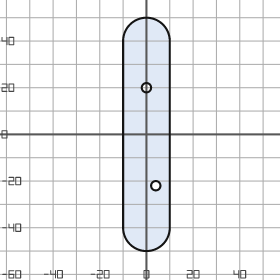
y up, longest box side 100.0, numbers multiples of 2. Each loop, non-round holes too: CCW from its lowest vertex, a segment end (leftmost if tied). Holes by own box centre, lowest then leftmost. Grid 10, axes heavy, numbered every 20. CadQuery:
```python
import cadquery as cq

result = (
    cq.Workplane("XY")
    .moveTo(-10.0, -40.0)
    .threePointArc((0.0, -50.0), (10.0, -40.0))
    .lineTo(10.0, 40.0)
    .threePointArc((0.0, 50.0), (-10.0, 40.0))
    .close()
    .moveTo(4.0, -22.0)
    .circle(2.0)
    .moveTo(0.0, 20.0)
    .circle(2.0)
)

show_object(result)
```